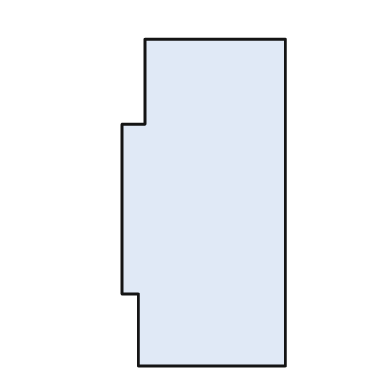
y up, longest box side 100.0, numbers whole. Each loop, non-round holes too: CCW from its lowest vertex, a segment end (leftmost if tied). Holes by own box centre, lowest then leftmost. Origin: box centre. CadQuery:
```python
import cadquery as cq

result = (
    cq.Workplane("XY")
    .moveTo(-20.0, -50.0)
    .lineTo(25.0, -50.0)
    .lineTo(25.0, 50.0)
    .lineTo(-18.0, 50.0)
    .lineTo(-18.0, 24.0)
    .lineTo(-25.0, 24.0)
    .lineTo(-25.0, -28.0)
    .lineTo(-20.0, -28.0)
    .close()
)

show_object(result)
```